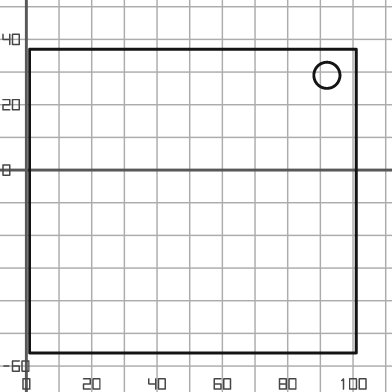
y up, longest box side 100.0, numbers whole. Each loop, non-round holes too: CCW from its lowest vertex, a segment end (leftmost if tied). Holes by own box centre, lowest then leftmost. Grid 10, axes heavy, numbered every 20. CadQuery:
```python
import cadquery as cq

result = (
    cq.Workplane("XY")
    .moveTo(1.0, -56.0)
    .lineTo(101.0, -56.0)
    .lineTo(101.0, 37.0)
    .lineTo(1.0, 37.0)
    .close()
    .moveTo(92.0, 29.0)
    .circle(4.0)
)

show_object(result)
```